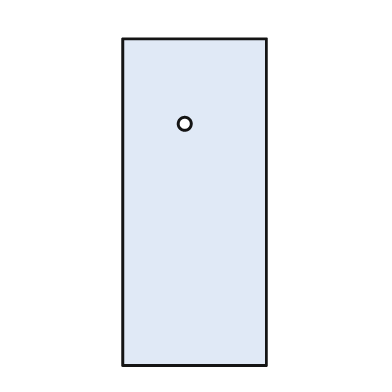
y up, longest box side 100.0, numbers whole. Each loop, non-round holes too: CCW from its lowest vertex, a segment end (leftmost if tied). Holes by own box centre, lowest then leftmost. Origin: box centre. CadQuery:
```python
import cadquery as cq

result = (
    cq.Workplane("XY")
    .moveTo(-22.0, -50.0)
    .lineTo(22.0, -50.0)
    .lineTo(22.0, 50.0)
    .lineTo(-22.0, 50.0)
    .close()
    .moveTo(-3.0, 24.0)
    .circle(2.0)
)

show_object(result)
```